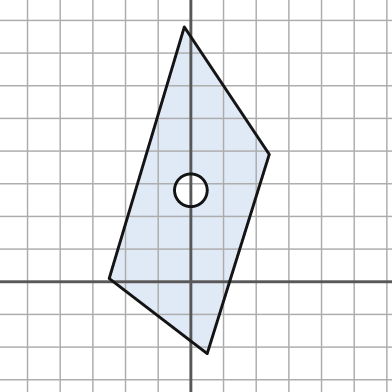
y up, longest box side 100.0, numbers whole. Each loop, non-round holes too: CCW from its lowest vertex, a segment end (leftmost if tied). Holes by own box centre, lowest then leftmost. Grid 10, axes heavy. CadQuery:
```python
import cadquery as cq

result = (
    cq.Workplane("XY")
    .moveTo(5.0, -22.0)
    .lineTo(24.0, 39.0)
    .lineTo(-2.0, 78.0)
    .lineTo(-25.0, 1.0)
    .close()
    .moveTo(0.0, 28.0)
    .circle(5.0)
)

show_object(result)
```